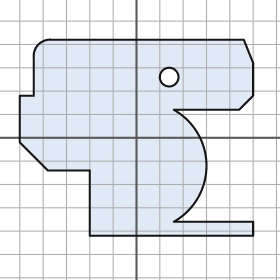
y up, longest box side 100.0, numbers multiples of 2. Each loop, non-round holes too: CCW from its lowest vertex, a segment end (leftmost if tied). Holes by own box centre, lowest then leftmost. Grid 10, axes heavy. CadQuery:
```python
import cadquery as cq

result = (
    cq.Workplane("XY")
    .moveTo(-20.0, -42.0)
    .lineTo(50.0, -42.0)
    .lineTo(50.0, -36.0)
    .lineTo(16.0, -36.0)
    .threePointArc((30.0, -12.0), (16.0, 12.0))
    .lineTo(44.0, 12.0)
    .lineTo(50.0, 18.0)
    .lineTo(50.0, 32.0)
    .lineTo(46.0, 42.0)
    .lineTo(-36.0, 42.0)
    .threePointArc((-42.0, 40.0), (-44.0, 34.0))
    .lineTo(-44.0, 18.0)
    .lineTo(-50.0, 18.0)
    .lineTo(-50.0, -2.0)
    .lineTo(-38.0, -14.0)
    .lineTo(-20.0, -14.0)
    .close()
    .moveTo(14.0, 26.0)
    .circle(4.0)
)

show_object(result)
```